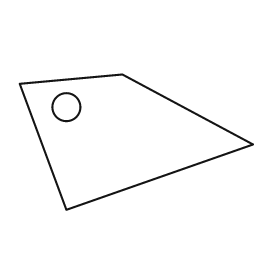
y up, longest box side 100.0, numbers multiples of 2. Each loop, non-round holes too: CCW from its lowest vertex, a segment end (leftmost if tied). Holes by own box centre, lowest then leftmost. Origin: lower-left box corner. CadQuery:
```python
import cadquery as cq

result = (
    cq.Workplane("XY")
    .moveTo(20.0, 0.0)
    .lineTo(100.0, 28.0)
    .lineTo(44.0, 58.0)
    .lineTo(0.0, 54.0)
    .close()
    .moveTo(20.0, 44.0)
    .circle(6.0)
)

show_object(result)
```